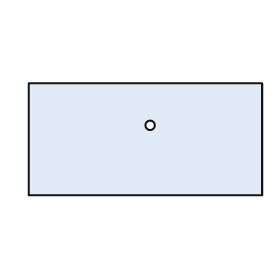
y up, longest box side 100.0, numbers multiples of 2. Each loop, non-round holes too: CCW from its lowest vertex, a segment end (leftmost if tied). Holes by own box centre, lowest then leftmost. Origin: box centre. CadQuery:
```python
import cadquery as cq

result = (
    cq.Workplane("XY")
    .moveTo(-50.0, -24.0)
    .lineTo(50.0, -24.0)
    .lineTo(50.0, 24.0)
    .lineTo(-50.0, 24.0)
    .close()
    .moveTo(2.0, 6.0)
    .circle(2.0)
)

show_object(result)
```